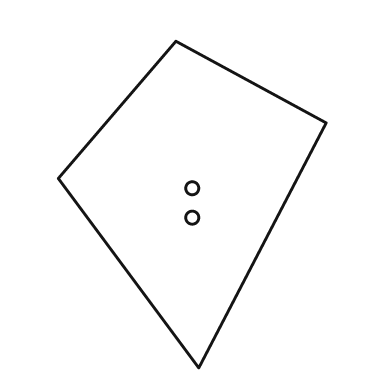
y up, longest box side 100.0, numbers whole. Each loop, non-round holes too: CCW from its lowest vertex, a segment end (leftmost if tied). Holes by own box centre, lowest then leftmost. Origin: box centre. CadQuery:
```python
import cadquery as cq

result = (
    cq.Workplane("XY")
    .moveTo(2.0, -50.0)
    .lineTo(41.0, 25.0)
    .lineTo(-5.0, 50.0)
    .lineTo(-41.0, 8.0)
    .close()
    .moveTo(0.0, -4.0)
    .circle(2.0)
    .moveTo(0.0, 5.0)
    .circle(2.0)
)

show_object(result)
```